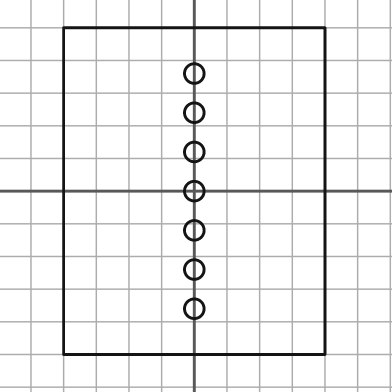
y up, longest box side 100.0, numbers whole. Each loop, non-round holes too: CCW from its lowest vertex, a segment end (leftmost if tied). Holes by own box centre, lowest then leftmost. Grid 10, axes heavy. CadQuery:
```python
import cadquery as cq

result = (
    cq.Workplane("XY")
    .moveTo(-40.0, -50.0)
    .lineTo(40.0, -50.0)
    .lineTo(40.0, 50.0)
    .lineTo(-40.0, 50.0)
    .close()
    .moveTo(0.0, -36.0)
    .circle(3.0)
    .moveTo(0.0, -24.0)
    .circle(3.0)
    .moveTo(0.0, -12.0)
    .circle(3.0)
    .moveTo(0.0, 0.0)
    .circle(3.0)
    .moveTo(0.0, 12.0)
    .circle(3.0)
    .moveTo(0.0, 24.0)
    .circle(3.0)
    .moveTo(0.0, 36.0)
    .circle(3.0)
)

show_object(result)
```